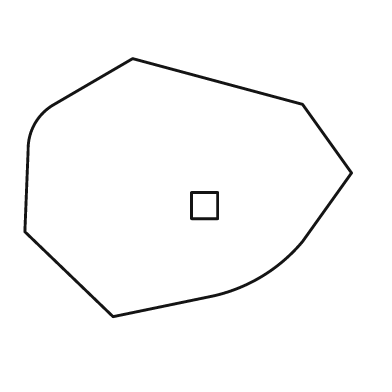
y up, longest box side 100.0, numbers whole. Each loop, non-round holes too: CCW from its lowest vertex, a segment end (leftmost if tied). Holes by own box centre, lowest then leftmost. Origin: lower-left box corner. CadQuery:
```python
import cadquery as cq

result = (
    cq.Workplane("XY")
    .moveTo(27.0, 0.0)
    .lineTo(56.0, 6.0)
    .threePointArc((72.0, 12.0), (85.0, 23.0))
    .lineTo(100.0, 44.0)
    .lineTo(85.0, 65.0)
    .lineTo(33.0, 79.0)
    .lineTo(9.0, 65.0)
    .threePointArc((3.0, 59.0), (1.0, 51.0))
    .lineTo(0.0, 26.0)
    .close()
    .moveTo(51.0, 30.0)
    .lineTo(59.0, 30.0)
    .lineTo(59.0, 38.0)
    .lineTo(51.0, 38.0)
    .close()
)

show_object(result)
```